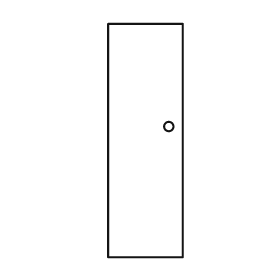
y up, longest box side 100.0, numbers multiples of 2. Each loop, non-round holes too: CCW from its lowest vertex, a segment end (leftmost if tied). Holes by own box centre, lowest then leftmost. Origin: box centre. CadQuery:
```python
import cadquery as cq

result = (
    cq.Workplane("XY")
    .moveTo(-16.0, -50.0)
    .lineTo(16.0, -50.0)
    .lineTo(16.0, 50.0)
    .lineTo(-16.0, 50.0)
    .close()
    .moveTo(10.0, 6.0)
    .circle(2.0)
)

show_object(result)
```